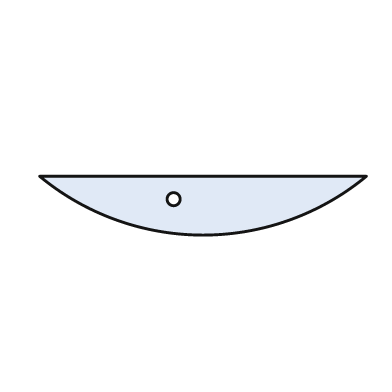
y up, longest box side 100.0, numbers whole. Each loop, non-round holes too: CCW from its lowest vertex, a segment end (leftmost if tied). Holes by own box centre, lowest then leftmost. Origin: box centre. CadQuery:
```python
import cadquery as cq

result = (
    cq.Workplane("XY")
    .moveTo(-50.0, 9.0)
    .threePointArc((0.0, -9.0), (50.0, 9.0))
    .close()
    .moveTo(-9.0, 2.0)
    .circle(2.0)
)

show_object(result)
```